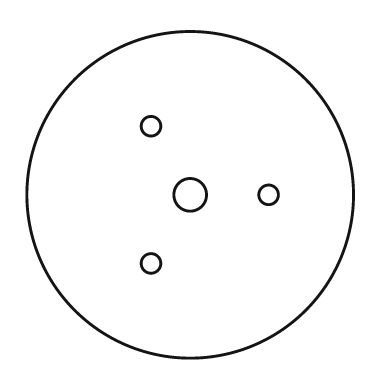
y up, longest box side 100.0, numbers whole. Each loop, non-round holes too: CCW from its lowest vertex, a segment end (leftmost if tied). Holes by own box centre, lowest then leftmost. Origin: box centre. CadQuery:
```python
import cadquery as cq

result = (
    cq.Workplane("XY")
    .moveTo(0.0, 0.0)
    .circle(50.0)
    .moveTo(-12.0, -21.0)
    .circle(3.0)
    .moveTo(0.0, 0.0)
    .circle(5.0)
    .moveTo(24.0, 0.0)
    .circle(3.0)
    .moveTo(-12.0, 21.0)
    .circle(3.0)
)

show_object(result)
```